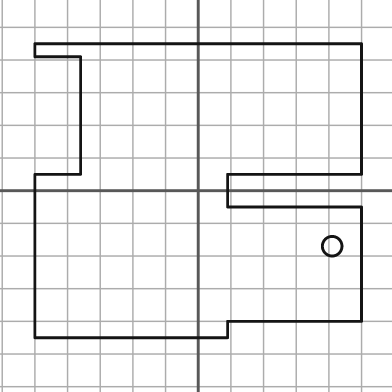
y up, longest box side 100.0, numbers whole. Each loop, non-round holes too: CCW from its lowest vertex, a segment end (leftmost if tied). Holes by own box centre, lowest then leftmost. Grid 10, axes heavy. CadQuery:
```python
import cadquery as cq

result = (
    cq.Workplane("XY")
    .moveTo(-50.0, -45.0)
    .lineTo(9.0, -45.0)
    .lineTo(9.0, -40.0)
    .lineTo(50.0, -40.0)
    .lineTo(50.0, -5.0)
    .lineTo(9.0, -5.0)
    .lineTo(9.0, 5.0)
    .lineTo(50.0, 5.0)
    .lineTo(50.0, 45.0)
    .lineTo(-50.0, 45.0)
    .lineTo(-50.0, 41.0)
    .lineTo(-36.0, 41.0)
    .lineTo(-36.0, 5.0)
    .lineTo(-50.0, 5.0)
    .close()
    .moveTo(41.0, -17.0)
    .circle(3.0)
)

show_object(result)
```